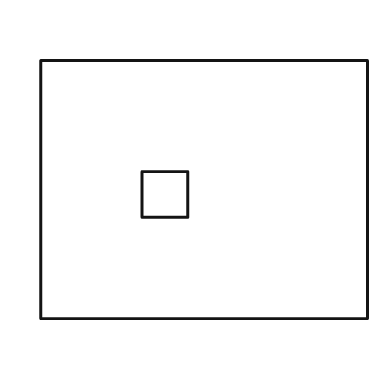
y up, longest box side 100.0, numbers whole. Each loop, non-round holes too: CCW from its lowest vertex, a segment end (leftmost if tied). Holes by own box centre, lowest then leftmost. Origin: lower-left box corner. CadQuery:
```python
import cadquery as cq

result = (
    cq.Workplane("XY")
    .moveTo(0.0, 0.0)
    .lineTo(100.0, 0.0)
    .lineTo(100.0, 79.0)
    .lineTo(0.0, 79.0)
    .close()
    .moveTo(31.0, 31.0)
    .lineTo(45.0, 31.0)
    .lineTo(45.0, 45.0)
    .lineTo(31.0, 45.0)
    .close()
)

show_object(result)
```